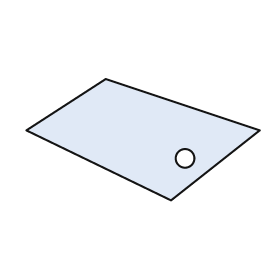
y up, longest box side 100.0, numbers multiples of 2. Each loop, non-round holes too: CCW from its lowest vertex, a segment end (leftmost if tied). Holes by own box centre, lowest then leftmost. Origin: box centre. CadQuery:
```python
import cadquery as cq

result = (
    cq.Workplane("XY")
    .moveTo(12.0, -26.0)
    .lineTo(50.0, 4.0)
    .lineTo(-16.0, 26.0)
    .lineTo(-50.0, 4.0)
    .close()
    .moveTo(18.0, -8.0)
    .circle(4.0)
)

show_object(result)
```